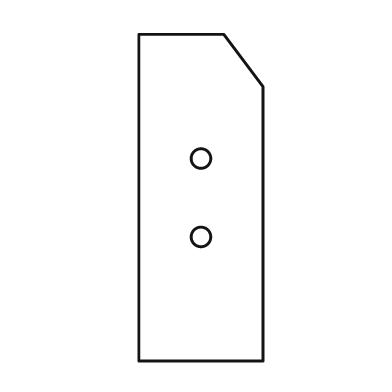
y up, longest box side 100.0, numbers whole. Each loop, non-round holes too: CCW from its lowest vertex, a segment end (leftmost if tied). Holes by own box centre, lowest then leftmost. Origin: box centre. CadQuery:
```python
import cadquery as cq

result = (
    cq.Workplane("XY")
    .moveTo(-19.0, -50.0)
    .lineTo(19.0, -50.0)
    .lineTo(19.0, 34.0)
    .lineTo(7.0, 50.0)
    .lineTo(-19.0, 50.0)
    .close()
    .moveTo(0.0, -12.0)
    .circle(3.0)
    .moveTo(0.0, 12.0)
    .circle(3.0)
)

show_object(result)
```